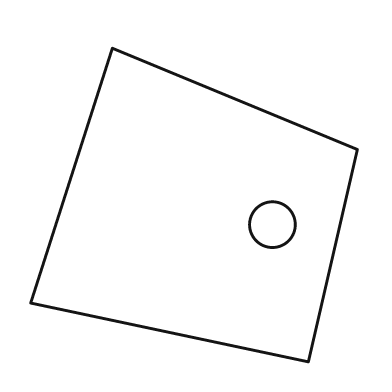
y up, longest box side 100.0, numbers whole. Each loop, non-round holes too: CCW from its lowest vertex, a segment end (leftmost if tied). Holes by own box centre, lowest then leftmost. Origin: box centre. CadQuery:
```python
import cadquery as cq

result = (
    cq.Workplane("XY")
    .moveTo(35.0, -48.0)
    .lineTo(50.0, 17.0)
    .lineTo(-25.0, 48.0)
    .lineTo(-50.0, -30.0)
    .close()
    .moveTo(24.0, -6.0)
    .circle(7.0)
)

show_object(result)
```